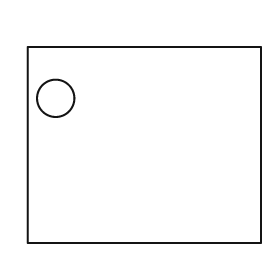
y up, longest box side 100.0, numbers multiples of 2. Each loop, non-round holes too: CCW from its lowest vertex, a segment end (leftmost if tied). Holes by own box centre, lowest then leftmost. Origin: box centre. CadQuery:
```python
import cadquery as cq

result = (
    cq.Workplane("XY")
    .moveTo(-50.0, -42.0)
    .lineTo(50.0, -42.0)
    .lineTo(50.0, 42.0)
    .lineTo(-50.0, 42.0)
    .close()
    .moveTo(-38.0, 20.0)
    .circle(8.0)
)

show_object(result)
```